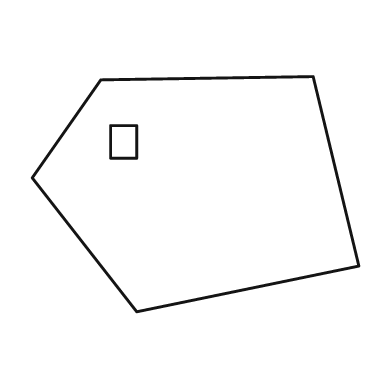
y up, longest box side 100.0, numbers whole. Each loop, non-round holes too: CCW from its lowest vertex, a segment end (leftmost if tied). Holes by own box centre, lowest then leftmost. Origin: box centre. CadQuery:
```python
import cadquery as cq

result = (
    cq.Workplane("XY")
    .moveTo(-18.0, -36.0)
    .lineTo(50.0, -22.0)
    .lineTo(36.0, 36.0)
    .lineTo(-29.0, 35.0)
    .lineTo(-50.0, 5.0)
    .close()
    .moveTo(-26.0, 11.0)
    .lineTo(-18.0, 11.0)
    .lineTo(-18.0, 21.0)
    .lineTo(-26.0, 21.0)
    .close()
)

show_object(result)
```